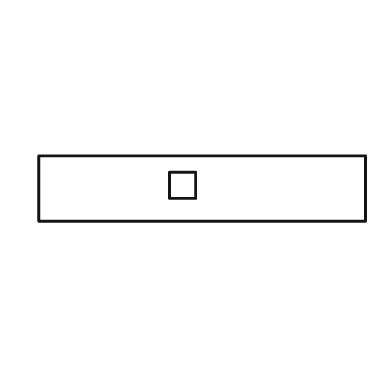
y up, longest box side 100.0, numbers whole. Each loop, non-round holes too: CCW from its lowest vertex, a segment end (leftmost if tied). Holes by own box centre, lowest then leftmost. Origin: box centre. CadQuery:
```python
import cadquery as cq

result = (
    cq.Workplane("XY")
    .moveTo(-50.0, -10.0)
    .lineTo(50.0, -10.0)
    .lineTo(50.0, 10.0)
    .lineTo(-50.0, 10.0)
    .close()
    .moveTo(-10.0, -3.0)
    .lineTo(-2.0, -3.0)
    .lineTo(-2.0, 5.0)
    .lineTo(-10.0, 5.0)
    .close()
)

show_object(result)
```